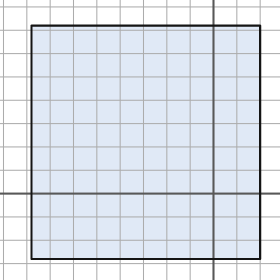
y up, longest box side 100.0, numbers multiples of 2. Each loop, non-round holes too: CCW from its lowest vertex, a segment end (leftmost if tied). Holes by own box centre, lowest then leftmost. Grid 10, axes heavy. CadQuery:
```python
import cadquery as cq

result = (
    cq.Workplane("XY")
    .moveTo(-78.0, -28.0)
    .lineTo(20.0, -28.0)
    .lineTo(20.0, 72.0)
    .lineTo(-78.0, 72.0)
    .close()
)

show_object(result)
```